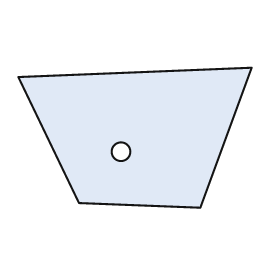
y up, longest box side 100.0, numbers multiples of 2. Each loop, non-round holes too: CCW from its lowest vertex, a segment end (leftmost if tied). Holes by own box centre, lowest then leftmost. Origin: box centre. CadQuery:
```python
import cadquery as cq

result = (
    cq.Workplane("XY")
    .moveTo(28.0, -30.0)
    .lineTo(50.0, 30.0)
    .lineTo(-50.0, 26.0)
    .lineTo(-24.0, -28.0)
    .close()
    .moveTo(-6.0, -6.0)
    .circle(4.0)
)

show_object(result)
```